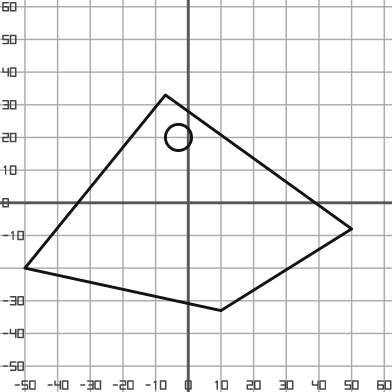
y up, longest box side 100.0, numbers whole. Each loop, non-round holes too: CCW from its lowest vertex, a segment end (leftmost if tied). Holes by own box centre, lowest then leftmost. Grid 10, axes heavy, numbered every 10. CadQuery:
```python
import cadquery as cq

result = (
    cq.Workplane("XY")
    .moveTo(10.0, -33.0)
    .lineTo(50.0, -8.0)
    .lineTo(-7.0, 33.0)
    .lineTo(-50.0, -20.0)
    .close()
    .moveTo(-3.0, 20.0)
    .circle(4.0)
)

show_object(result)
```